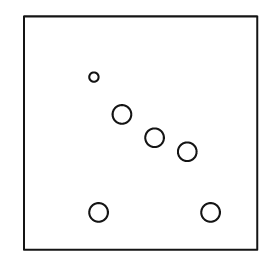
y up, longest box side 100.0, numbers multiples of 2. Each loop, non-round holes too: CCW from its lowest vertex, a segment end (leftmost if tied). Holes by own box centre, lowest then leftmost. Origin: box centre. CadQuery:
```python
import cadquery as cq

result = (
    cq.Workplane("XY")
    .moveTo(-50.0, -50.0)
    .lineTo(50.0, -50.0)
    .lineTo(50.0, 50.0)
    .lineTo(-50.0, 50.0)
    .close()
    .moveTo(-18.0, -34.0)
    .circle(4.0)
    .moveTo(30.0, -34.0)
    .circle(4.0)
    .moveTo(20.0, -8.0)
    .circle(4.0)
    .moveTo(6.0, -2.0)
    .circle(4.0)
    .moveTo(-8.0, 8.0)
    .circle(4.0)
    .moveTo(-20.0, 24.0)
    .circle(2.0)
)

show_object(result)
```